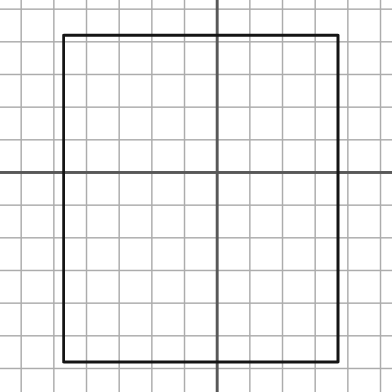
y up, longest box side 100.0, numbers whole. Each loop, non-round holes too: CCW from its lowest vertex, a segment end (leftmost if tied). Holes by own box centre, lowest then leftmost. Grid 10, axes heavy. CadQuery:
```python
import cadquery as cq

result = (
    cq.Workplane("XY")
    .moveTo(-47.0, -58.0)
    .lineTo(37.0, -58.0)
    .lineTo(37.0, 42.0)
    .lineTo(-47.0, 42.0)
    .close()
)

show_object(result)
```